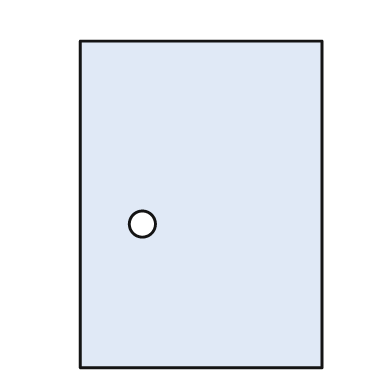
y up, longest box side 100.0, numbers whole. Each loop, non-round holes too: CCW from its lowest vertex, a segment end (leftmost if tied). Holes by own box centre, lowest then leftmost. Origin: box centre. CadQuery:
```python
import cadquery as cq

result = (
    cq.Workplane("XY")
    .moveTo(-37.0, -50.0)
    .lineTo(37.0, -50.0)
    .lineTo(37.0, 50.0)
    .lineTo(-37.0, 50.0)
    .close()
    .moveTo(-18.0, -6.0)
    .circle(4.0)
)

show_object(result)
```